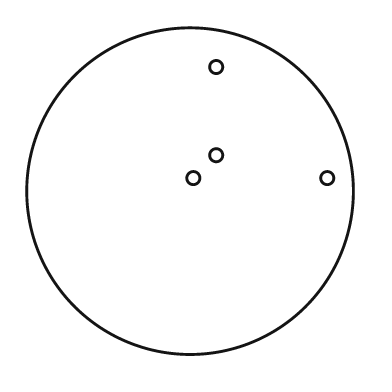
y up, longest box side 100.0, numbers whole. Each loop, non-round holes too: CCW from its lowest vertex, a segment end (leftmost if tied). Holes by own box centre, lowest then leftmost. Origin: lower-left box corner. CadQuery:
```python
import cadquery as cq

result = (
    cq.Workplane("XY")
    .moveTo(50.0, 50.0)
    .circle(50.0)
    .moveTo(51.0, 54.0)
    .circle(2.0)
    .moveTo(92.0, 54.0)
    .circle(2.0)
    .moveTo(58.0, 61.0)
    .circle(2.0)
    .moveTo(58.0, 88.0)
    .circle(2.0)
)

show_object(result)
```